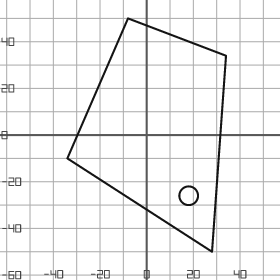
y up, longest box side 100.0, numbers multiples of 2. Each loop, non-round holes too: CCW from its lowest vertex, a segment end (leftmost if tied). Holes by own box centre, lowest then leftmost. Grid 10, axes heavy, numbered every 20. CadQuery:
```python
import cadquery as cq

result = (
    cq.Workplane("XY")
    .moveTo(28.0, -50.0)
    .lineTo(34.0, 34.0)
    .lineTo(-8.0, 50.0)
    .lineTo(-34.0, -10.0)
    .close()
    .moveTo(18.0, -26.0)
    .circle(4.0)
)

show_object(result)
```